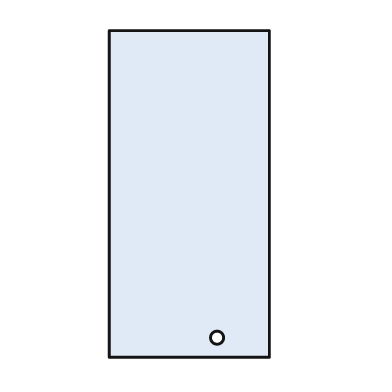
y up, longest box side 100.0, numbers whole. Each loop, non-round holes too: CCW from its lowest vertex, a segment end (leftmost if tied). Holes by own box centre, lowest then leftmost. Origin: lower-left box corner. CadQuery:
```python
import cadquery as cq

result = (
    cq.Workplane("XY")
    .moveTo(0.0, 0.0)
    .lineTo(49.0, 0.0)
    .lineTo(49.0, 100.0)
    .lineTo(0.0, 100.0)
    .close()
    .moveTo(33.0, 6.0)
    .circle(2.0)
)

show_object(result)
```